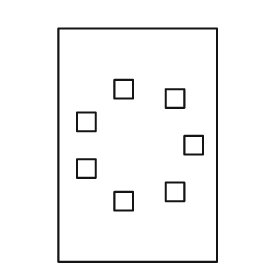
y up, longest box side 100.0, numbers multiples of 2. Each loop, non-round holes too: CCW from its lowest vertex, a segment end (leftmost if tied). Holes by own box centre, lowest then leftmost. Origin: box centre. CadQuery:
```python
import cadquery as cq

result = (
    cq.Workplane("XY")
    .moveTo(-34.0, -50.0)
    .lineTo(34.0, -50.0)
    .lineTo(34.0, 50.0)
    .lineTo(-34.0, 50.0)
    .close()
    .moveTo(-10.0, -28.0)
    .lineTo(-2.0, -28.0)
    .lineTo(-2.0, -20.0)
    .lineTo(-10.0, -20.0)
    .close()
    .moveTo(12.0, -24.0)
    .lineTo(20.0, -24.0)
    .lineTo(20.0, -16.0)
    .lineTo(12.0, -16.0)
    .close()
    .moveTo(-26.0, -14.0)
    .lineTo(-18.0, -14.0)
    .lineTo(-18.0, -6.0)
    .lineTo(-26.0, -6.0)
    .close()
    .moveTo(20.0, -4.0)
    .lineTo(28.0, -4.0)
    .lineTo(28.0, 4.0)
    .lineTo(20.0, 4.0)
    .close()
    .moveTo(-26.0, 6.0)
    .lineTo(-18.0, 6.0)
    .lineTo(-18.0, 14.0)
    .lineTo(-26.0, 14.0)
    .close()
    .moveTo(12.0, 16.0)
    .lineTo(20.0, 16.0)
    .lineTo(20.0, 24.0)
    .lineTo(12.0, 24.0)
    .close()
    .moveTo(-10.0, 20.0)
    .lineTo(-2.0, 20.0)
    .lineTo(-2.0, 28.0)
    .lineTo(-10.0, 28.0)
    .close()
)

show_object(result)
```